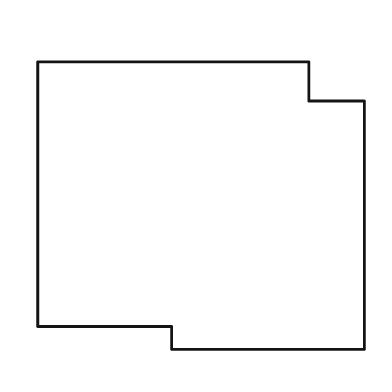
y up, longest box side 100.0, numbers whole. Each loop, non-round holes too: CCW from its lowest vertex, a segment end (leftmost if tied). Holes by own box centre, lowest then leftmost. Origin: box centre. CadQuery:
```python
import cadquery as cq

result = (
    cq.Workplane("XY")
    .moveTo(-9.0, -44.0)
    .lineTo(50.0, -44.0)
    .lineTo(50.0, 32.0)
    .lineTo(33.0, 32.0)
    .lineTo(33.0, 44.0)
    .lineTo(-50.0, 44.0)
    .lineTo(-50.0, -37.0)
    .lineTo(-9.0, -37.0)
    .close()
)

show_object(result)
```